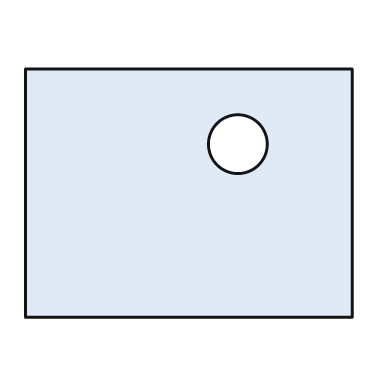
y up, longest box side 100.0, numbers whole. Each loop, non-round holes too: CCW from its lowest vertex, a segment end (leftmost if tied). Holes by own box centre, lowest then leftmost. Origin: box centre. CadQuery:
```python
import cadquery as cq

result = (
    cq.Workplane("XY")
    .moveTo(-50.0, -38.0)
    .lineTo(50.0, -38.0)
    .lineTo(50.0, 38.0)
    .lineTo(-50.0, 38.0)
    .close()
    .moveTo(15.0, 15.0)
    .circle(9.0)
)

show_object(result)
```